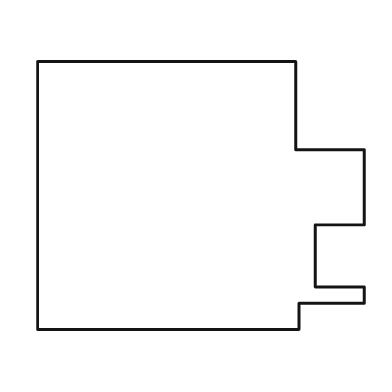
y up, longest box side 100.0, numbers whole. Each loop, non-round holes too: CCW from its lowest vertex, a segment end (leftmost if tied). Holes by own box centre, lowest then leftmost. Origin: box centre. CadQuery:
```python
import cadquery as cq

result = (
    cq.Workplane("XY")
    .moveTo(-50.0, -41.0)
    .lineTo(30.0, -41.0)
    .lineTo(30.0, -33.0)
    .lineTo(50.0, -33.0)
    .lineTo(50.0, -28.0)
    .lineTo(35.0, -28.0)
    .lineTo(35.0, -9.0)
    .lineTo(50.0, -9.0)
    .lineTo(50.0, 14.0)
    .lineTo(29.0, 14.0)
    .lineTo(29.0, 41.0)
    .lineTo(-50.0, 41.0)
    .close()
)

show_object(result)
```